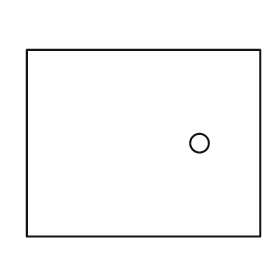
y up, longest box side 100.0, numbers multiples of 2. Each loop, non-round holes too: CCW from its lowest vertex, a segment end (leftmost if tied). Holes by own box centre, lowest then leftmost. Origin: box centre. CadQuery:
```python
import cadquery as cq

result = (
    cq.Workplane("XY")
    .moveTo(-50.0, -40.0)
    .lineTo(50.0, -40.0)
    .lineTo(50.0, 40.0)
    .lineTo(-50.0, 40.0)
    .close()
    .moveTo(24.0, 0.0)
    .circle(4.0)
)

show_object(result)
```